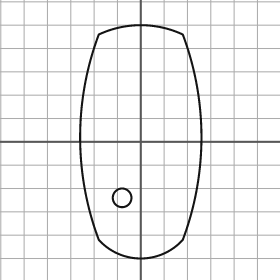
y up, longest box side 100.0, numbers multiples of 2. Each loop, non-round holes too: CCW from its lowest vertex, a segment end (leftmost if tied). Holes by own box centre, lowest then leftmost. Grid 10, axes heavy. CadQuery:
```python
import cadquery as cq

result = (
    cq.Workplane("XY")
    .moveTo(-18.0, -42.0)
    .threePointArc((0.0, -50.0), (18.0, -42.0))
    .threePointArc((26.0, 2.0), (18.0, 46.0))
    .threePointArc((0.0, 50.0), (-18.0, 46.0))
    .threePointArc((-26.0, 2.0), (-18.0, -42.0))
    .close()
    .moveTo(-8.0, -24.0)
    .circle(4.0)
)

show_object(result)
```